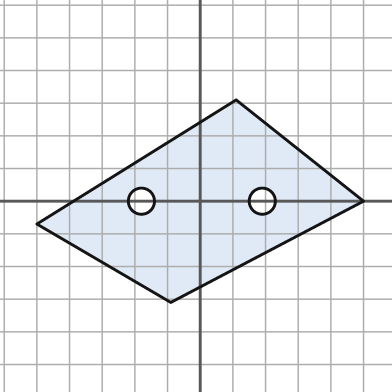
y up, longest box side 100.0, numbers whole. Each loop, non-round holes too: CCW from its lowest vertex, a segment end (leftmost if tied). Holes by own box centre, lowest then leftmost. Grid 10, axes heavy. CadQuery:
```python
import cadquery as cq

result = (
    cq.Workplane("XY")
    .moveTo(-9.0, -31.0)
    .lineTo(50.0, 0.0)
    .lineTo(11.0, 31.0)
    .lineTo(-50.0, -7.0)
    .close()
    .moveTo(-18.0, 0.0)
    .circle(4.0)
    .moveTo(19.0, 0.0)
    .circle(4.0)
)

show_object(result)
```